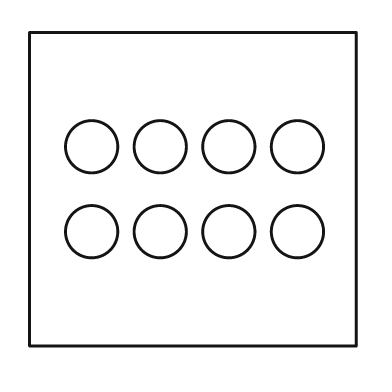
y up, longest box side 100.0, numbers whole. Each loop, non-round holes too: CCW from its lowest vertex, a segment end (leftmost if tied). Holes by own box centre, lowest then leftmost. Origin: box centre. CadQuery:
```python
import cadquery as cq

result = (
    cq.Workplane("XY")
    .moveTo(-50.0, -48.0)
    .lineTo(50.0, -48.0)
    .lineTo(50.0, 48.0)
    .lineTo(-50.0, 48.0)
    .close()
    .moveTo(-31.0, -13.0)
    .circle(8.0)
    .moveTo(-10.0, -13.0)
    .circle(8.0)
    .moveTo(11.0, -13.0)
    .circle(8.0)
    .moveTo(32.0, -13.0)
    .circle(8.0)
    .moveTo(-31.0, 13.0)
    .circle(8.0)
    .moveTo(-10.0, 13.0)
    .circle(8.0)
    .moveTo(11.0, 13.0)
    .circle(8.0)
    .moveTo(32.0, 13.0)
    .circle(8.0)
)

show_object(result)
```